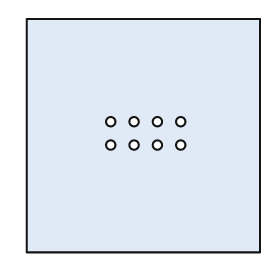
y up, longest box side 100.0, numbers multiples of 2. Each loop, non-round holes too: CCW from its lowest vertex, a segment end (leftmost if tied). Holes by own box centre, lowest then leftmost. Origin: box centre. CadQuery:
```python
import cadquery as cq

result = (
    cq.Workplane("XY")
    .moveTo(-50.0, -50.0)
    .lineTo(50.0, -50.0)
    .lineTo(50.0, 50.0)
    .lineTo(-50.0, 50.0)
    .close()
    .moveTo(-14.0, -4.0)
    .circle(2.0)
    .moveTo(-4.0, -4.0)
    .circle(2.0)
    .moveTo(6.0, -4.0)
    .circle(2.0)
    .moveTo(16.0, -4.0)
    .circle(2.0)
    .moveTo(-14.0, 6.0)
    .circle(2.0)
    .moveTo(-4.0, 6.0)
    .circle(2.0)
    .moveTo(6.0, 6.0)
    .circle(2.0)
    .moveTo(16.0, 6.0)
    .circle(2.0)
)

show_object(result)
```